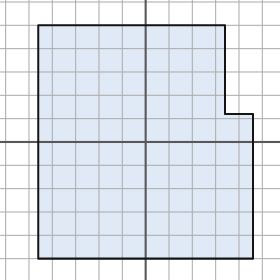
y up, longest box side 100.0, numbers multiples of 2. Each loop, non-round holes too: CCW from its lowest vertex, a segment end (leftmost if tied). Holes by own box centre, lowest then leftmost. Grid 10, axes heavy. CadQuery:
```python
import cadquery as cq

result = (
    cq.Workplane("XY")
    .moveTo(-46.0, -50.0)
    .lineTo(46.0, -50.0)
    .lineTo(46.0, 12.0)
    .lineTo(34.0, 12.0)
    .lineTo(34.0, 50.0)
    .lineTo(-46.0, 50.0)
    .close()
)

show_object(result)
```